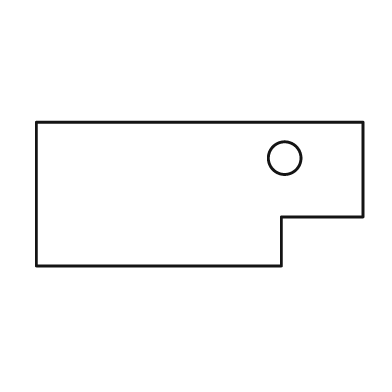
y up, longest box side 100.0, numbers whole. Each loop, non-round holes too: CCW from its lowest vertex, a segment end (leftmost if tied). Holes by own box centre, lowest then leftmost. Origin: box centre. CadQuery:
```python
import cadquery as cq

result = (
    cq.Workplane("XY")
    .moveTo(-50.0, -22.0)
    .lineTo(25.0, -22.0)
    .lineTo(25.0, -7.0)
    .lineTo(50.0, -7.0)
    .lineTo(50.0, 22.0)
    .lineTo(-50.0, 22.0)
    .close()
    .moveTo(26.0, 11.0)
    .circle(5.0)
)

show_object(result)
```